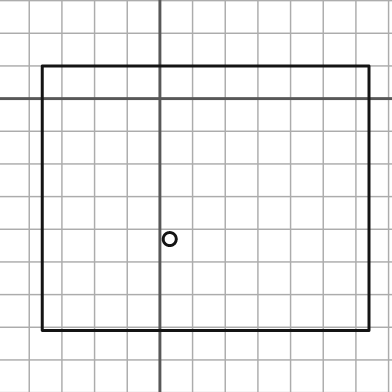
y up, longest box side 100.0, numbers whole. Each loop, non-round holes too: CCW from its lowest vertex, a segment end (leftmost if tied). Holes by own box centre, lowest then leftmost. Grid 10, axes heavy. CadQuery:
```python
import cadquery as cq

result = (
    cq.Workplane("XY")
    .moveTo(-36.0, -71.0)
    .lineTo(64.0, -71.0)
    .lineTo(64.0, 10.0)
    .lineTo(-36.0, 10.0)
    .close()
    .moveTo(3.0, -43.0)
    .circle(2.0)
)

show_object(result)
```